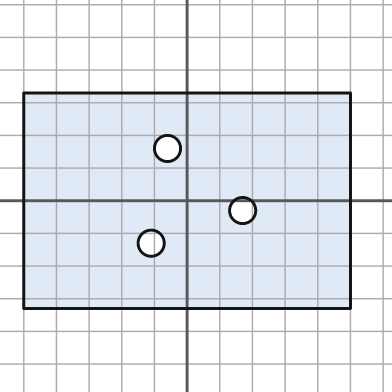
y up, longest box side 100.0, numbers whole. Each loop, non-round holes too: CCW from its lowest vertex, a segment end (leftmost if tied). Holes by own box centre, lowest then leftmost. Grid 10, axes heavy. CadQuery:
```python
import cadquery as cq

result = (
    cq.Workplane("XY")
    .moveTo(-50.0, -33.0)
    .lineTo(50.0, -33.0)
    .lineTo(50.0, 33.0)
    .lineTo(-50.0, 33.0)
    .close()
    .moveTo(-11.0, -13.0)
    .circle(4.0)
    .moveTo(17.0, -3.0)
    .circle(4.0)
    .moveTo(-6.0, 16.0)
    .circle(4.0)
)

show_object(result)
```